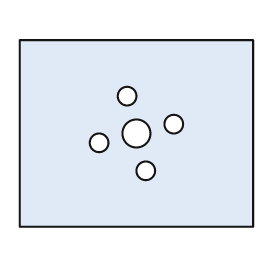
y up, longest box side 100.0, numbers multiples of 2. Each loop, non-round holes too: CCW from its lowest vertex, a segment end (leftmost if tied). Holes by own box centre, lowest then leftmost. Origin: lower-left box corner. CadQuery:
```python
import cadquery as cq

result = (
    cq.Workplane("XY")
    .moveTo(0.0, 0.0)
    .lineTo(100.0, 0.0)
    .lineTo(100.0, 80.0)
    .lineTo(0.0, 80.0)
    .close()
    .moveTo(54.0, 24.0)
    .circle(4.0)
    .moveTo(34.0, 36.0)
    .circle(4.0)
    .moveTo(50.0, 40.0)
    .circle(6.0)
    .moveTo(66.0, 44.0)
    .circle(4.0)
    .moveTo(46.0, 56.0)
    .circle(4.0)
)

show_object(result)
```